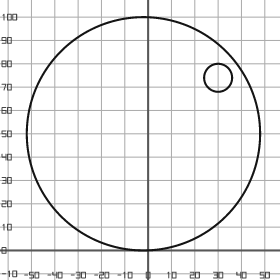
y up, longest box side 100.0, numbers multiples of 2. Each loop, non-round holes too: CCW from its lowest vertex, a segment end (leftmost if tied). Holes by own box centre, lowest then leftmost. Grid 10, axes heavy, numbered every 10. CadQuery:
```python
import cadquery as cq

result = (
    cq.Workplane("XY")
    .moveTo(-2.0, 50.0)
    .circle(50.0)
    .moveTo(30.0, 74.0)
    .circle(6.0)
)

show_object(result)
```